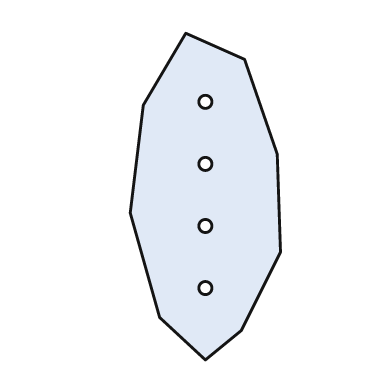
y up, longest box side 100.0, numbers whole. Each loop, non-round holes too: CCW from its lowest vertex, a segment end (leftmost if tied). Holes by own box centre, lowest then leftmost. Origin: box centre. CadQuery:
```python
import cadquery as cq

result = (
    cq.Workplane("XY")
    .moveTo(0.0, -50.0)
    .lineTo(11.0, -41.0)
    .lineTo(23.0, -17.0)
    .lineTo(22.0, 13.0)
    .lineTo(12.0, 42.0)
    .lineTo(-6.0, 50.0)
    .lineTo(-19.0, 28.0)
    .lineTo(-23.0, -5.0)
    .lineTo(-14.0, -37.0)
    .close()
    .moveTo(0.0, -28.0)
    .circle(2.0)
    .moveTo(0.0, -9.0)
    .circle(2.0)
    .moveTo(0.0, 10.0)
    .circle(2.0)
    .moveTo(0.0, 29.0)
    .circle(2.0)
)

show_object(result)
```